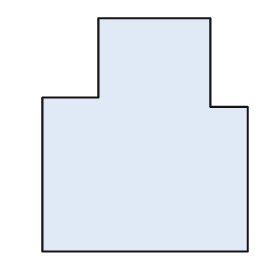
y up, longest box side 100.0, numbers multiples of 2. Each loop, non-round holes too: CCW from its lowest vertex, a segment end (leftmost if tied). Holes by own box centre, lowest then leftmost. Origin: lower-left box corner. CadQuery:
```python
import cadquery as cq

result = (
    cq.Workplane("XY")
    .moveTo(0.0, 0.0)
    .lineTo(88.0, 0.0)
    .lineTo(88.0, 62.0)
    .lineTo(72.0, 62.0)
    .lineTo(72.0, 100.0)
    .lineTo(24.0, 100.0)
    .lineTo(24.0, 66.0)
    .lineTo(0.0, 66.0)
    .close()
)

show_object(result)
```